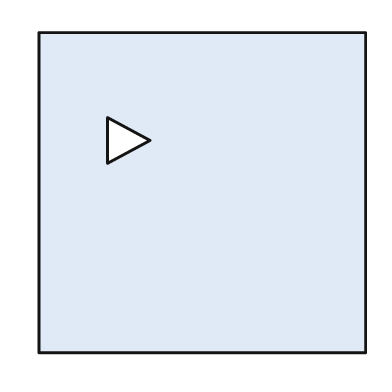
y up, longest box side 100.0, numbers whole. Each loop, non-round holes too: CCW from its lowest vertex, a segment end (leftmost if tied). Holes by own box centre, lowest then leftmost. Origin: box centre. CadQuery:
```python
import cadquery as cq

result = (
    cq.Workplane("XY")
    .moveTo(-50.0, -49.0)
    .lineTo(50.0, -49.0)
    .lineTo(50.0, 49.0)
    .lineTo(-50.0, 49.0)
    .close()
    .moveTo(-29.0, 9.0)
    .lineTo(-16.0, 16.0)
    .lineTo(-29.0, 23.0)
    .close()
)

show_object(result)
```